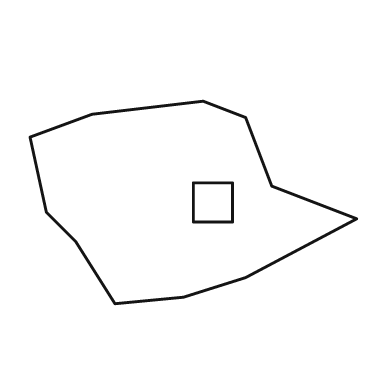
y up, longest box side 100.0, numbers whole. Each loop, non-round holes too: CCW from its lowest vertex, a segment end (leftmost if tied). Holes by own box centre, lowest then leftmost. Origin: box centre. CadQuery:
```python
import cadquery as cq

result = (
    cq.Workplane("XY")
    .moveTo(-24.0, -31.0)
    .lineTo(-3.0, -29.0)
    .lineTo(16.0, -23.0)
    .lineTo(50.0, -5.0)
    .lineTo(24.0, 5.0)
    .lineTo(16.0, 26.0)
    .lineTo(3.0, 31.0)
    .lineTo(-31.0, 27.0)
    .lineTo(-50.0, 20.0)
    .lineTo(-45.0, -3.0)
    .lineTo(-36.0, -12.0)
    .close()
    .moveTo(0.0, -6.0)
    .lineTo(12.0, -6.0)
    .lineTo(12.0, 6.0)
    .lineTo(0.0, 6.0)
    .close()
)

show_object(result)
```